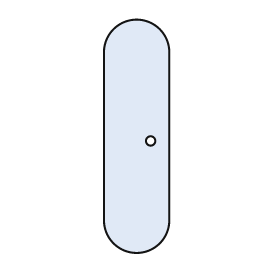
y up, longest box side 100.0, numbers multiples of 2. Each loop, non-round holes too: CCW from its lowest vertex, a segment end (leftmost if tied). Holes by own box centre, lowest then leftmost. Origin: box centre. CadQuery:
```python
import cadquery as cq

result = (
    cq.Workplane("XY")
    .moveTo(-14.0, -36.0)
    .threePointArc((0.0, -50.0), (14.0, -36.0))
    .lineTo(14.0, 36.0)
    .threePointArc((0.0, 50.0), (-14.0, 36.0))
    .close()
    .moveTo(6.0, -2.0)
    .circle(2.0)
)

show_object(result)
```